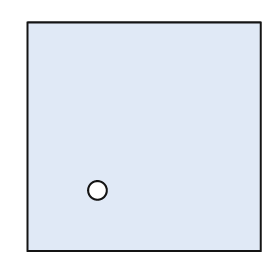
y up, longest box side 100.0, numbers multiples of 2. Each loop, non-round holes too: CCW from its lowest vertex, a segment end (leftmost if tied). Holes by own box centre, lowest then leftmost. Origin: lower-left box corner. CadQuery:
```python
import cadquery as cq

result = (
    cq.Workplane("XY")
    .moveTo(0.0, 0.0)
    .lineTo(100.0, 0.0)
    .lineTo(100.0, 98.0)
    .lineTo(0.0, 98.0)
    .close()
    .moveTo(30.0, 26.0)
    .circle(4.0)
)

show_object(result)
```